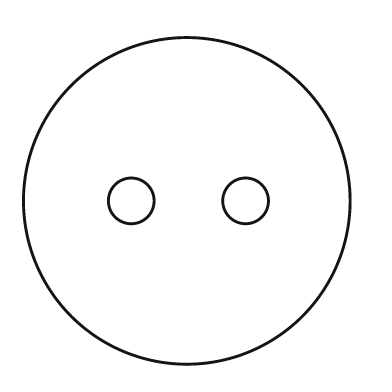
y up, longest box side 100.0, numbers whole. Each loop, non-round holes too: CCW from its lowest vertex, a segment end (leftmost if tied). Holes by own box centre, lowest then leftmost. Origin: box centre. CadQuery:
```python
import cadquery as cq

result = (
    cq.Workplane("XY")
    .moveTo(0.0, 0.0)
    .circle(50.0)
    .moveTo(-17.0, 0.0)
    .circle(7.0)
    .moveTo(18.0, 0.0)
    .circle(7.0)
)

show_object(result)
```